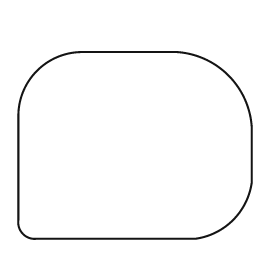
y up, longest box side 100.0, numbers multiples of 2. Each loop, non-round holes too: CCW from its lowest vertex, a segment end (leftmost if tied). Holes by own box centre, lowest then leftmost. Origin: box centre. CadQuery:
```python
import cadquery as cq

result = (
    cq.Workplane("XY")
    .moveTo(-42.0, -40.0)
    .lineTo(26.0, -40.0)
    .threePointArc((42.0, -32.0), (50.0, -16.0))
    .lineTo(50.0, 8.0)
    .threePointArc((40.0, 30.0), (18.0, 40.0))
    .lineTo(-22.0, 40.0)
    .threePointArc((-42.0, 32.0), (-50.0, 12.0))
    .lineTo(-50.0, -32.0)
    .threePointArc((-48.0, -38.0), (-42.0, -40.0))
    .close()
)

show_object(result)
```